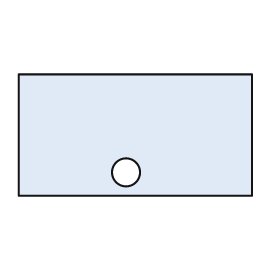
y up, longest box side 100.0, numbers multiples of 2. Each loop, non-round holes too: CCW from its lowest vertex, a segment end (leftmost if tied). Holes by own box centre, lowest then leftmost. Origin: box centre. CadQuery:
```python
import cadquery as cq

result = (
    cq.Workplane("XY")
    .moveTo(-50.0, -26.0)
    .lineTo(50.0, -26.0)
    .lineTo(50.0, 26.0)
    .lineTo(-50.0, 26.0)
    .close()
    .moveTo(-4.0, -16.0)
    .circle(6.0)
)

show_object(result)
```